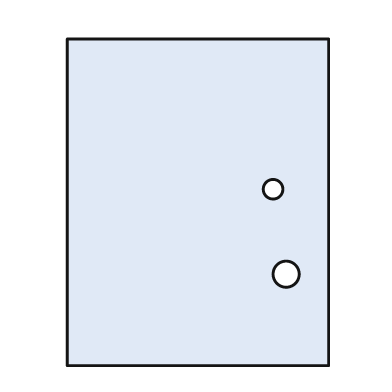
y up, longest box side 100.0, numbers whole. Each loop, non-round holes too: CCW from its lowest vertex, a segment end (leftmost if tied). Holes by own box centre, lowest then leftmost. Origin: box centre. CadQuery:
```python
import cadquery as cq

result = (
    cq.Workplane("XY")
    .moveTo(-40.0, -50.0)
    .lineTo(40.0, -50.0)
    .lineTo(40.0, 50.0)
    .lineTo(-40.0, 50.0)
    .close()
    .moveTo(27.0, -22.0)
    .circle(4.0)
    .moveTo(23.0, 4.0)
    .circle(3.0)
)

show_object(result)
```